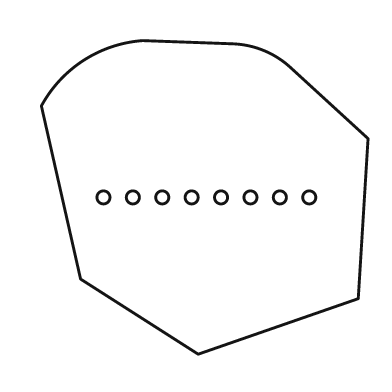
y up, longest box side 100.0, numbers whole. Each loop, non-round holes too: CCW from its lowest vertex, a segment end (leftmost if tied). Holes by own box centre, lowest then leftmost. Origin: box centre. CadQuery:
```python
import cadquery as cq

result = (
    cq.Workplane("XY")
    .moveTo(-2.0, -48.0)
    .lineTo(47.0, -31.0)
    .lineTo(50.0, 18.0)
    .lineTo(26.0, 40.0)
    .threePointArc((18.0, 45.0), (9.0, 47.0))
    .lineTo(-19.0, 48.0)
    .threePointArc((-37.0, 42.0), (-50.0, 28.0))
    .lineTo(-38.0, -25.0)
    .close()
    .moveTo(-31.0, 0.0)
    .circle(2.0)
    .moveTo(-22.0, 0.0)
    .circle(2.0)
    .moveTo(-13.0, 0.0)
    .circle(2.0)
    .moveTo(-4.0, 0.0)
    .circle(2.0)
    .moveTo(5.0, 0.0)
    .circle(2.0)
    .moveTo(14.0, 0.0)
    .circle(2.0)
    .moveTo(23.0, 0.0)
    .circle(2.0)
    .moveTo(32.0, 0.0)
    .circle(2.0)
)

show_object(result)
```